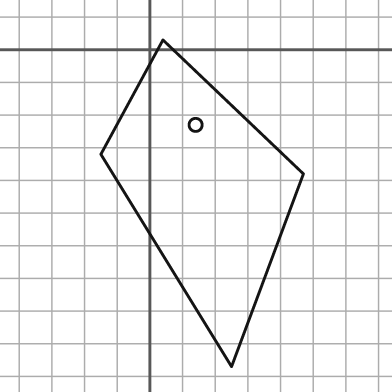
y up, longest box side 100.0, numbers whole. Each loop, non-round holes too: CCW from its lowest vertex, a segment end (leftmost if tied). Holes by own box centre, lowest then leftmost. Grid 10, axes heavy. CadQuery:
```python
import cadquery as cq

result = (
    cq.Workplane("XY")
    .moveTo(25.0, -97.0)
    .lineTo(47.0, -38.0)
    .lineTo(4.0, 3.0)
    .lineTo(-15.0, -32.0)
    .close()
    .moveTo(14.0, -23.0)
    .circle(2.0)
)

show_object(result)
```